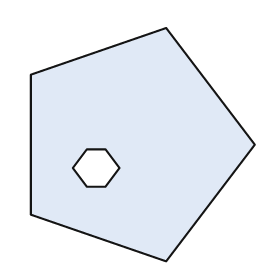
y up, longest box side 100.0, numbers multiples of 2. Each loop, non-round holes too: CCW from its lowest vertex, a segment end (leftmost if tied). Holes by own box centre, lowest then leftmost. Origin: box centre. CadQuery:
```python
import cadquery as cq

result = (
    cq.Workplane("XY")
    .moveTo(10.0, -50.0)
    .lineTo(48.0, 0.0)
    .lineTo(10.0, 50.0)
    .lineTo(-48.0, 30.0)
    .lineTo(-48.0, -30.0)
    .close()
    .moveTo(-24.0, -18.0)
    .lineTo(-16.0, -18.0)
    .lineTo(-10.0, -10.0)
    .lineTo(-16.0, -2.0)
    .lineTo(-24.0, -2.0)
    .lineTo(-30.0, -10.0)
    .close()
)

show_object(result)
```